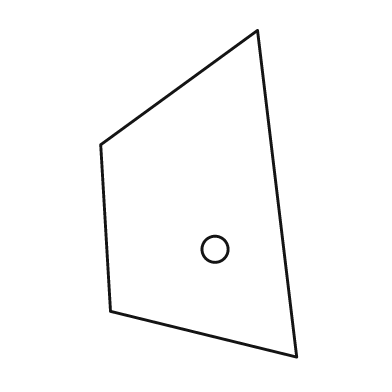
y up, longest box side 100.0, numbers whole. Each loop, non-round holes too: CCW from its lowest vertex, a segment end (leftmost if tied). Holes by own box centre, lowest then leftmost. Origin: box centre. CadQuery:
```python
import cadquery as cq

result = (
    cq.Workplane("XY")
    .moveTo(30.0, -50.0)
    .lineTo(18.0, 50.0)
    .lineTo(-30.0, 15.0)
    .lineTo(-27.0, -36.0)
    .close()
    .moveTo(5.0, -17.0)
    .circle(4.0)
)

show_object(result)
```